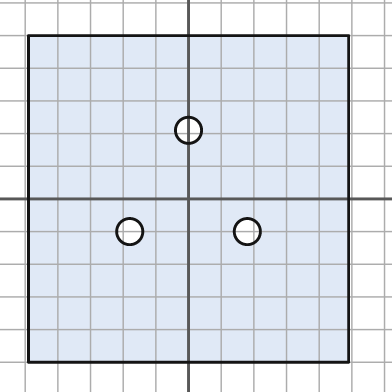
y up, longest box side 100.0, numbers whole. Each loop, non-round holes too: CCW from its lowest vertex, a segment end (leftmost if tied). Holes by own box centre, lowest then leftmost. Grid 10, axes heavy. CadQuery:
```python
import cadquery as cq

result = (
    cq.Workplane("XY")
    .moveTo(-49.0, -50.0)
    .lineTo(49.0, -50.0)
    .lineTo(49.0, 50.0)
    .lineTo(-49.0, 50.0)
    .close()
    .moveTo(-18.0, -10.0)
    .circle(4.0)
    .moveTo(18.0, -10.0)
    .circle(4.0)
    .moveTo(0.0, 21.0)
    .circle(4.0)
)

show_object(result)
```